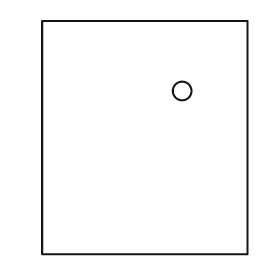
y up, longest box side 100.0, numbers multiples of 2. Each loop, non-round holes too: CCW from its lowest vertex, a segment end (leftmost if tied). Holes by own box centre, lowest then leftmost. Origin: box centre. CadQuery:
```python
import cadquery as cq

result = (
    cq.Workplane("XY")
    .moveTo(-44.0, -50.0)
    .lineTo(44.0, -50.0)
    .lineTo(44.0, 50.0)
    .lineTo(-44.0, 50.0)
    .close()
    .moveTo(16.0, 20.0)
    .circle(4.0)
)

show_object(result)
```